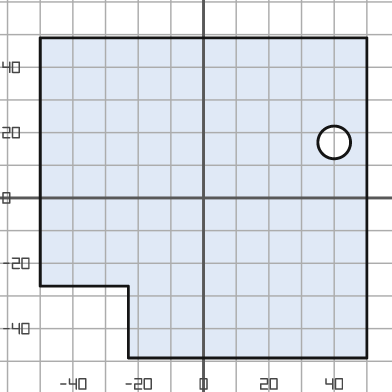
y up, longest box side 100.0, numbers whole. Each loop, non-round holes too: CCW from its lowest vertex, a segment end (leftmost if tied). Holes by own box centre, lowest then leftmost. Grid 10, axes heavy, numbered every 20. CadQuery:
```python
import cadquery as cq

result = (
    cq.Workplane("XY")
    .moveTo(-23.0, -49.0)
    .lineTo(50.0, -49.0)
    .lineTo(50.0, 49.0)
    .lineTo(-50.0, 49.0)
    .lineTo(-50.0, -27.0)
    .lineTo(-23.0, -27.0)
    .close()
    .moveTo(40.0, 17.0)
    .circle(5.0)
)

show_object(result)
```